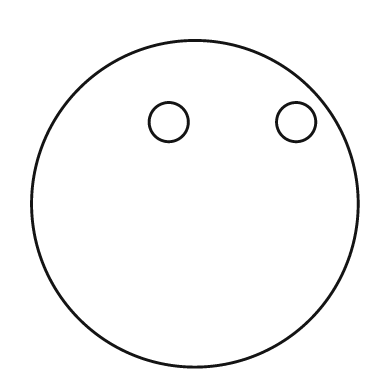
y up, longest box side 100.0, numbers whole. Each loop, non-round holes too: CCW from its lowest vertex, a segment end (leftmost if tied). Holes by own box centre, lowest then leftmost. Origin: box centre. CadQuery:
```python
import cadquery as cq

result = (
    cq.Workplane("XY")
    .moveTo(0.0, 0.0)
    .circle(50.0)
    .moveTo(-8.0, 25.0)
    .circle(6.0)
    .moveTo(31.0, 25.0)
    .circle(6.0)
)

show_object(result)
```